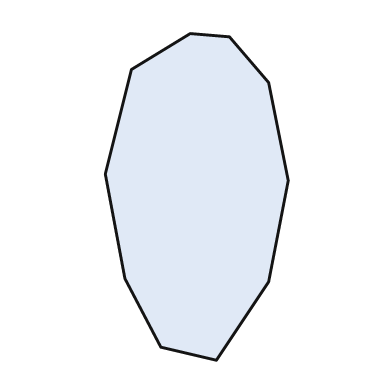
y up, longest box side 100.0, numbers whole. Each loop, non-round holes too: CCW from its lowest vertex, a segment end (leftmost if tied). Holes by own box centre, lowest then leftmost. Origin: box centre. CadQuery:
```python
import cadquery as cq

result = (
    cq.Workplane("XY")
    .moveTo(6.0, -50.0)
    .lineTo(22.0, -26.0)
    .lineTo(28.0, 5.0)
    .lineTo(22.0, 35.0)
    .lineTo(10.0, 49.0)
    .lineTo(-2.0, 50.0)
    .lineTo(-20.0, 39.0)
    .lineTo(-28.0, 7.0)
    .lineTo(-22.0, -25.0)
    .lineTo(-11.0, -46.0)
    .close()
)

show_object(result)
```